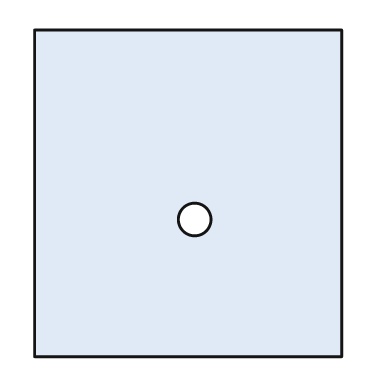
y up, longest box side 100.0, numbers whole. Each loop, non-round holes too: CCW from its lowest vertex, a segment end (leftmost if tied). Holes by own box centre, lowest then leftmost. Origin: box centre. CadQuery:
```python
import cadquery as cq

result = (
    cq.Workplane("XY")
    .moveTo(-47.0, -50.0)
    .lineTo(47.0, -50.0)
    .lineTo(47.0, 50.0)
    .lineTo(-47.0, 50.0)
    .close()
    .moveTo(2.0, -8.0)
    .circle(5.0)
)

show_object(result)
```